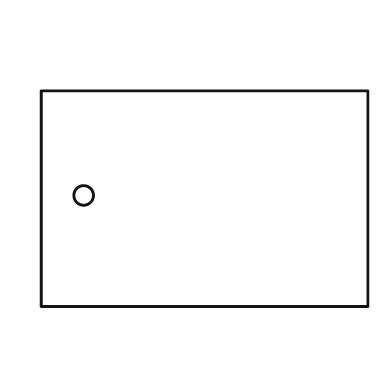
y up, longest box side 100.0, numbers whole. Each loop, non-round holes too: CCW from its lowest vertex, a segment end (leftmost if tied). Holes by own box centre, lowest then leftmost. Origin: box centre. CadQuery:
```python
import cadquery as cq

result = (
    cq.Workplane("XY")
    .moveTo(-50.0, -33.0)
    .lineTo(50.0, -33.0)
    .lineTo(50.0, 33.0)
    .lineTo(-50.0, 33.0)
    .close()
    .moveTo(-37.0, 1.0)
    .circle(3.0)
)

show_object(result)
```